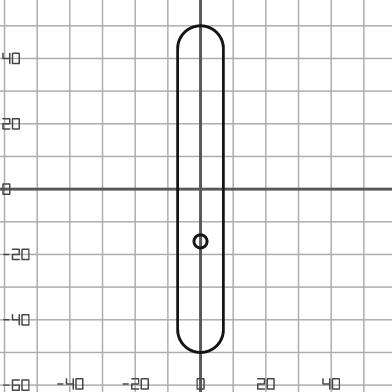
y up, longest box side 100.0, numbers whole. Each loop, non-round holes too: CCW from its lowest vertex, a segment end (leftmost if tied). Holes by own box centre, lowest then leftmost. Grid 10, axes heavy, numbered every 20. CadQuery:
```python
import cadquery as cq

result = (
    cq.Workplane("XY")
    .moveTo(-7.0, -43.0)
    .threePointArc((0.0, -50.0), (7.0, -43.0))
    .lineTo(7.0, 43.0)
    .threePointArc((0.0, 50.0), (-7.0, 43.0))
    .close()
    .moveTo(0.0, -16.0)
    .circle(2.0)
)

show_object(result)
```